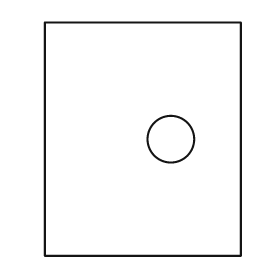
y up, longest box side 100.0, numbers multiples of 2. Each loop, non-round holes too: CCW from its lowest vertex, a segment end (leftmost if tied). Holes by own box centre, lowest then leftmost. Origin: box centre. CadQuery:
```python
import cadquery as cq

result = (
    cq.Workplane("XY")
    .moveTo(-42.0, -50.0)
    .lineTo(42.0, -50.0)
    .lineTo(42.0, 50.0)
    .lineTo(-42.0, 50.0)
    .close()
    .moveTo(12.0, 0.0)
    .circle(10.0)
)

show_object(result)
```